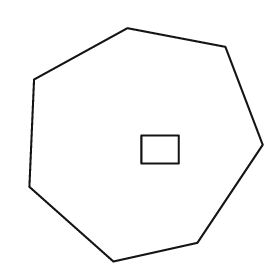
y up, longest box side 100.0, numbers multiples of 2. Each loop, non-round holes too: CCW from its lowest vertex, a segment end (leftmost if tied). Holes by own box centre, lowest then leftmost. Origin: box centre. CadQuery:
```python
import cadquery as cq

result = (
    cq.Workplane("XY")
    .moveTo(-14.0, -50.0)
    .lineTo(22.0, -42.0)
    .lineTo(50.0, 0.0)
    .lineTo(34.0, 42.0)
    .lineTo(-8.0, 50.0)
    .lineTo(-48.0, 28.0)
    .lineTo(-50.0, -18.0)
    .close()
    .moveTo(-2.0, -8.0)
    .lineTo(14.0, -8.0)
    .lineTo(14.0, 4.0)
    .lineTo(-2.0, 4.0)
    .close()
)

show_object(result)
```